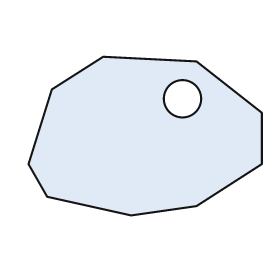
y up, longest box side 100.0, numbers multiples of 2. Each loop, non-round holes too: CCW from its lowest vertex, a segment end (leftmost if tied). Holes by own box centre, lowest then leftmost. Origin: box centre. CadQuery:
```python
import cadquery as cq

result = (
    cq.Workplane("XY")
    .moveTo(-6.0, -34.0)
    .lineTo(22.0, -30.0)
    .lineTo(50.0, -12.0)
    .lineTo(50.0, 10.0)
    .lineTo(22.0, 32.0)
    .lineTo(-18.0, 34.0)
    .lineTo(-40.0, 20.0)
    .lineTo(-50.0, -12.0)
    .lineTo(-42.0, -26.0)
    .close()
    .moveTo(16.0, 16.0)
    .circle(8.0)
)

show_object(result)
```